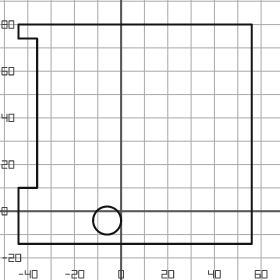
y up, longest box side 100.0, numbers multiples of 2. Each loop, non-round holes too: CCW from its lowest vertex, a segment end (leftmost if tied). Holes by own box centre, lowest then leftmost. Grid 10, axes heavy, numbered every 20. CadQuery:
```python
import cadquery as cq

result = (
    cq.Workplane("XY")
    .moveTo(-44.0, -14.0)
    .lineTo(56.0, -14.0)
    .lineTo(56.0, 80.0)
    .lineTo(-44.0, 80.0)
    .lineTo(-44.0, 74.0)
    .lineTo(-36.0, 74.0)
    .lineTo(-36.0, 10.0)
    .lineTo(-44.0, 10.0)
    .close()
    .moveTo(-6.0, -4.0)
    .circle(6.0)
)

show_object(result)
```